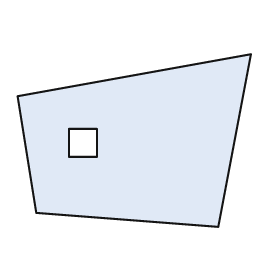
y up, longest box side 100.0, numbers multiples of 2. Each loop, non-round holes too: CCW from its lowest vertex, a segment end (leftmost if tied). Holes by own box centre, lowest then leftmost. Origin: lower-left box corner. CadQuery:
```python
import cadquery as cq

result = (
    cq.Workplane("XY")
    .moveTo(86.0, 0.0)
    .lineTo(100.0, 74.0)
    .lineTo(0.0, 56.0)
    .lineTo(8.0, 6.0)
    .close()
    .moveTo(22.0, 30.0)
    .lineTo(34.0, 30.0)
    .lineTo(34.0, 42.0)
    .lineTo(22.0, 42.0)
    .close()
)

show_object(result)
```